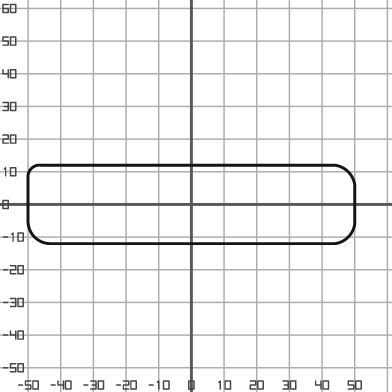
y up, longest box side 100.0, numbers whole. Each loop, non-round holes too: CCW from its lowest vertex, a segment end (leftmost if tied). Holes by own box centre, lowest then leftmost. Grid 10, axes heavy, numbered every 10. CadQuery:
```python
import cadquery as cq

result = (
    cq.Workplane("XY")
    .moveTo(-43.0, -12.0)
    .lineTo(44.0, -12.0)
    .threePointArc((48.0, -10.0), (50.0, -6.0))
    .lineTo(50.0, 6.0)
    .threePointArc((48.0, 10.0), (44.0, 12.0))
    .lineTo(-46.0, 12.0)
    .threePointArc((-49.0, 11.0), (-50.0, 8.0))
    .lineTo(-50.0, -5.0)
    .threePointArc((-48.0, -10.0), (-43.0, -12.0))
    .close()
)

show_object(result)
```